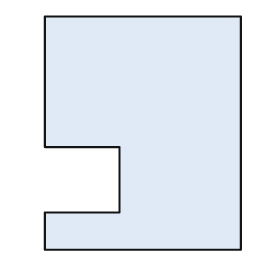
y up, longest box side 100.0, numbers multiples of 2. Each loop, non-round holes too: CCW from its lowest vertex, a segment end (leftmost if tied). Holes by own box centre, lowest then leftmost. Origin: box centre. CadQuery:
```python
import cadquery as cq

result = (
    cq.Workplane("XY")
    .moveTo(-42.0, -50.0)
    .lineTo(42.0, -50.0)
    .lineTo(42.0, 50.0)
    .lineTo(-42.0, 50.0)
    .lineTo(-42.0, -6.0)
    .lineTo(-10.0, -6.0)
    .lineTo(-10.0, -34.0)
    .lineTo(-42.0, -34.0)
    .close()
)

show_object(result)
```